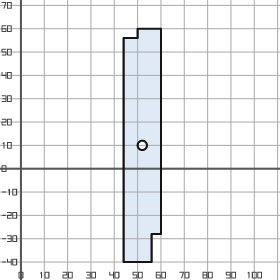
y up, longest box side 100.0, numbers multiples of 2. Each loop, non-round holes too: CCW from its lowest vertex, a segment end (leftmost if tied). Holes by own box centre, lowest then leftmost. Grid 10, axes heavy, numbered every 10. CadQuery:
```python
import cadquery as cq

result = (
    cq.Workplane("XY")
    .moveTo(44.0, -40.0)
    .lineTo(56.0, -40.0)
    .lineTo(56.0, -28.0)
    .lineTo(60.0, -28.0)
    .lineTo(60.0, 60.0)
    .lineTo(50.0, 60.0)
    .lineTo(50.0, 56.0)
    .lineTo(44.0, 56.0)
    .close()
    .moveTo(52.0, 10.0)
    .circle(2.0)
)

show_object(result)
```